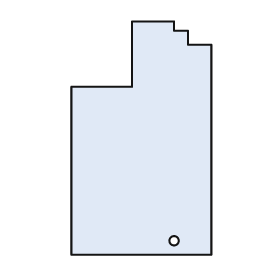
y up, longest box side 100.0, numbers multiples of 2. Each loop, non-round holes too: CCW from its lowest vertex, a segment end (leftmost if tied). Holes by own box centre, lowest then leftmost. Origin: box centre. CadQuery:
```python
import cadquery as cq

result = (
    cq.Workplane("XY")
    .moveTo(-30.0, -50.0)
    .lineTo(30.0, -50.0)
    .lineTo(30.0, 40.0)
    .lineTo(20.0, 40.0)
    .lineTo(20.0, 46.0)
    .lineTo(14.0, 46.0)
    .lineTo(14.0, 50.0)
    .lineTo(-4.0, 50.0)
    .lineTo(-4.0, 22.0)
    .lineTo(-30.0, 22.0)
    .close()
    .moveTo(14.0, -44.0)
    .circle(2.0)
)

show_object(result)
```